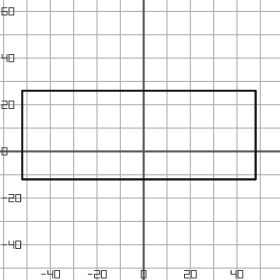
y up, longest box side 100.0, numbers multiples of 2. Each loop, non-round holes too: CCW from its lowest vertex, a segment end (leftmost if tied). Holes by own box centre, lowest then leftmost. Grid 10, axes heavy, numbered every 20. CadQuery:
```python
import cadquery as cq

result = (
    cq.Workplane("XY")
    .moveTo(-52.0, -12.0)
    .lineTo(48.0, -12.0)
    .lineTo(48.0, 26.0)
    .lineTo(-52.0, 26.0)
    .close()
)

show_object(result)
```